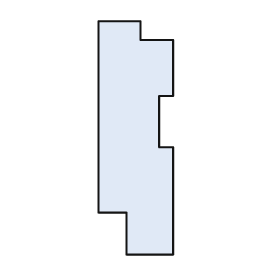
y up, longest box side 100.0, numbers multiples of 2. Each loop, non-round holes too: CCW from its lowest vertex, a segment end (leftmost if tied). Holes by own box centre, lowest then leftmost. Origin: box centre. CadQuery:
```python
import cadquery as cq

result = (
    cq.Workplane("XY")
    .moveTo(-4.0, -50.0)
    .lineTo(16.0, -50.0)
    .lineTo(16.0, -4.0)
    .lineTo(10.0, -4.0)
    .lineTo(10.0, 18.0)
    .lineTo(16.0, 18.0)
    .lineTo(16.0, 42.0)
    .lineTo(2.0, 42.0)
    .lineTo(2.0, 50.0)
    .lineTo(-16.0, 50.0)
    .lineTo(-16.0, -32.0)
    .lineTo(-4.0, -32.0)
    .close()
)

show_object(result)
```